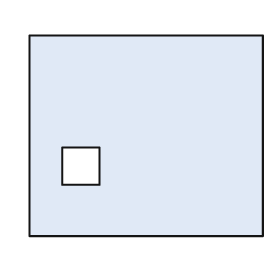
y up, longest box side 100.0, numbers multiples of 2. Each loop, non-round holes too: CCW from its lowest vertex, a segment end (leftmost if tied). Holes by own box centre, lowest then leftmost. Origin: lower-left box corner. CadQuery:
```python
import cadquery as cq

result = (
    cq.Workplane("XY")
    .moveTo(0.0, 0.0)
    .lineTo(100.0, 0.0)
    .lineTo(100.0, 86.0)
    .lineTo(0.0, 86.0)
    .close()
    .moveTo(14.0, 22.0)
    .lineTo(30.0, 22.0)
    .lineTo(30.0, 38.0)
    .lineTo(14.0, 38.0)
    .close()
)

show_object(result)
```